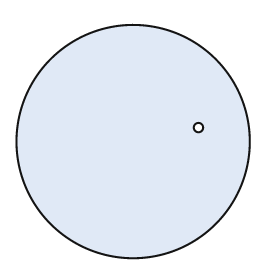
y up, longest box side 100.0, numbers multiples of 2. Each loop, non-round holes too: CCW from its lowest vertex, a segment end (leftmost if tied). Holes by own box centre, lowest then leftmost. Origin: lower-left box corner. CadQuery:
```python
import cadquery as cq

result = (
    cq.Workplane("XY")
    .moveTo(50.0, 50.0)
    .circle(50.0)
    .moveTo(78.0, 56.0)
    .circle(2.0)
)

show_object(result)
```